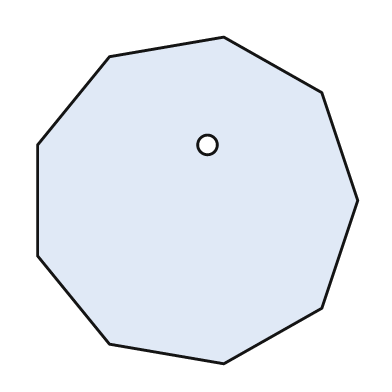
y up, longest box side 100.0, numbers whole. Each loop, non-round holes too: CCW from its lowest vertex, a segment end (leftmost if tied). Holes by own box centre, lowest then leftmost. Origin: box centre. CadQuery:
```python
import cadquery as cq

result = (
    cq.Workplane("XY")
    .moveTo(8.0, -50.0)
    .lineTo(38.0, -33.0)
    .lineTo(49.0, 0.0)
    .lineTo(38.0, 33.0)
    .lineTo(8.0, 50.0)
    .lineTo(-27.0, 44.0)
    .lineTo(-49.0, 17.0)
    .lineTo(-49.0, -17.0)
    .lineTo(-27.0, -44.0)
    .close()
    .moveTo(3.0, 17.0)
    .circle(3.0)
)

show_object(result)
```